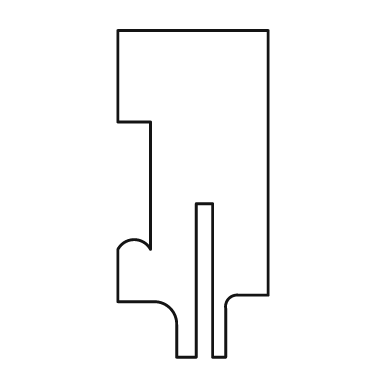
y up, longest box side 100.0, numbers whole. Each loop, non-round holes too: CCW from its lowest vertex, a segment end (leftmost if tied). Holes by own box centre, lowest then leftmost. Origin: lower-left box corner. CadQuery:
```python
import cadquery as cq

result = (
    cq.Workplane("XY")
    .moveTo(18.0, 0.0)
    .lineTo(24.0, 0.0)
    .lineTo(24.0, 47.0)
    .lineTo(29.0, 47.0)
    .lineTo(29.0, 0.0)
    .lineTo(33.0, 0.0)
    .lineTo(33.0, 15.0)
    .threePointArc((34.0, 18.0), (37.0, 19.0))
    .lineTo(46.0, 19.0)
    .lineTo(46.0, 100.0)
    .lineTo(0.0, 100.0)
    .lineTo(0.0, 72.0)
    .lineTo(10.0, 72.0)
    .lineTo(10.0, 33.0)
    .threePointArc((5.0, 36.0), (0.0, 33.0))
    .lineTo(0.0, 17.0)
    .lineTo(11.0, 17.0)
    .threePointArc((16.0, 15.0), (18.0, 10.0))
    .close()
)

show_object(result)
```